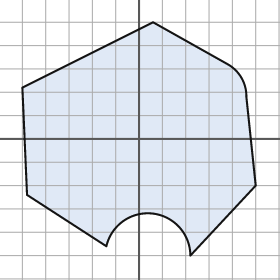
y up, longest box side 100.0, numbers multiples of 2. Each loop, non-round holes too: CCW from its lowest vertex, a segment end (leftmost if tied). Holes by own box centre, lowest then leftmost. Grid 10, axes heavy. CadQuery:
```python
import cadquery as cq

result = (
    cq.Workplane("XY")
    .moveTo(22.0, -50.0)
    .lineTo(50.0, -20.0)
    .lineTo(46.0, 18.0)
    .threePointArc((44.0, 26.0), (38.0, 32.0))
    .lineTo(6.0, 50.0)
    .lineTo(-50.0, 22.0)
    .lineTo(-48.0, -24.0)
    .lineTo(-14.0, -46.0)
    .threePointArc((6.0, -32.0), (22.0, -50.0))
    .close()
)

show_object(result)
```